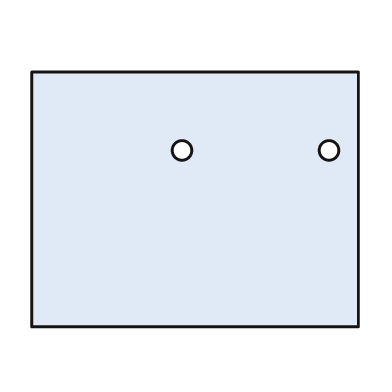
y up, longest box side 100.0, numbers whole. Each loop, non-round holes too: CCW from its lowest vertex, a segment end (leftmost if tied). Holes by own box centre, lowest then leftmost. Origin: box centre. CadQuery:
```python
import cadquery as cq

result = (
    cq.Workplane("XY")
    .moveTo(-50.0, -39.0)
    .lineTo(50.0, -39.0)
    .lineTo(50.0, 39.0)
    .lineTo(-50.0, 39.0)
    .close()
    .moveTo(-4.0, 15.0)
    .circle(3.0)
    .moveTo(41.0, 15.0)
    .circle(3.0)
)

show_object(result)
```